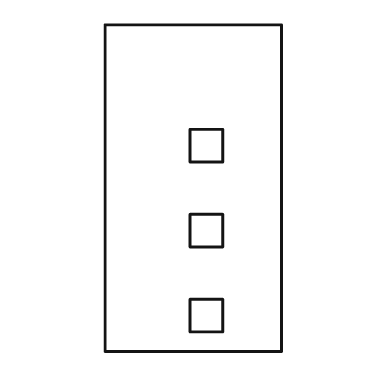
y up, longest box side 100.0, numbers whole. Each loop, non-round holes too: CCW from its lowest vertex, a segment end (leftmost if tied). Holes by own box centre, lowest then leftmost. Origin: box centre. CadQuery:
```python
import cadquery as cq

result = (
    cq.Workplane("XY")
    .moveTo(-27.0, -50.0)
    .lineTo(27.0, -50.0)
    .lineTo(27.0, 50.0)
    .lineTo(-27.0, 50.0)
    .close()
    .moveTo(-1.0, -44.0)
    .lineTo(9.0, -44.0)
    .lineTo(9.0, -34.0)
    .lineTo(-1.0, -34.0)
    .close()
    .moveTo(-1.0, -18.0)
    .lineTo(9.0, -18.0)
    .lineTo(9.0, -8.0)
    .lineTo(-1.0, -8.0)
    .close()
    .moveTo(-1.0, 8.0)
    .lineTo(9.0, 8.0)
    .lineTo(9.0, 18.0)
    .lineTo(-1.0, 18.0)
    .close()
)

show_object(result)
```